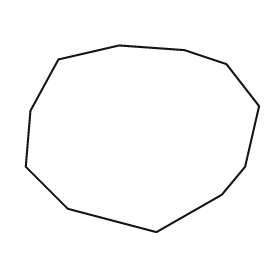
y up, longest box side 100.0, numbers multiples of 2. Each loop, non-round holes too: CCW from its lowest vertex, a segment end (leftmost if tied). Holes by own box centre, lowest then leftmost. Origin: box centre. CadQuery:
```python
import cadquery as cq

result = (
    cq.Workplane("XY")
    .moveTo(6.0, -40.0)
    .lineTo(34.0, -24.0)
    .lineTo(44.0, -12.0)
    .lineTo(50.0, 14.0)
    .lineTo(36.0, 32.0)
    .lineTo(18.0, 38.0)
    .lineTo(-10.0, 40.0)
    .lineTo(-36.0, 34.0)
    .lineTo(-48.0, 12.0)
    .lineTo(-50.0, -12.0)
    .lineTo(-32.0, -30.0)
    .close()
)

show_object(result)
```